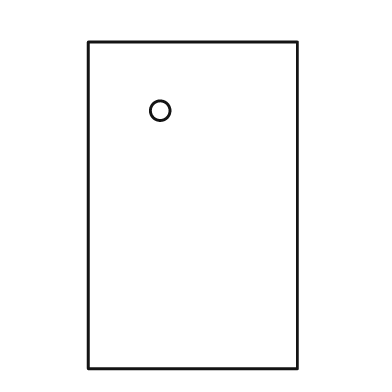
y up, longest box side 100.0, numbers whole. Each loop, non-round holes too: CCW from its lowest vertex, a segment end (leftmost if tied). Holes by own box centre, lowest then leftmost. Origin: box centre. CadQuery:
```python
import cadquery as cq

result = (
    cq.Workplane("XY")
    .moveTo(-32.0, -50.0)
    .lineTo(32.0, -50.0)
    .lineTo(32.0, 50.0)
    .lineTo(-32.0, 50.0)
    .close()
    .moveTo(-10.0, 29.0)
    .circle(3.0)
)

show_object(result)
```